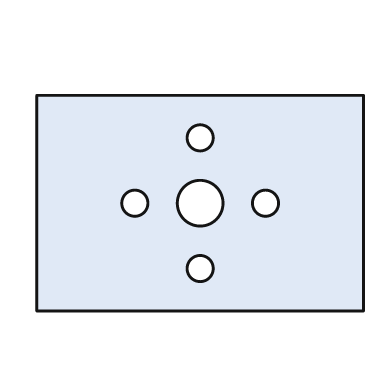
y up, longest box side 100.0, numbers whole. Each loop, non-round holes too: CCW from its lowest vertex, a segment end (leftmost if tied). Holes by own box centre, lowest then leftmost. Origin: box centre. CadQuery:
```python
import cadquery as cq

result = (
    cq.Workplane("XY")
    .moveTo(-50.0, -33.0)
    .lineTo(50.0, -33.0)
    .lineTo(50.0, 33.0)
    .lineTo(-50.0, 33.0)
    .close()
    .moveTo(0.0, -20.0)
    .circle(4.0)
    .moveTo(-20.0, 0.0)
    .circle(4.0)
    .moveTo(0.0, 0.0)
    .circle(7.0)
    .moveTo(20.0, 0.0)
    .circle(4.0)
    .moveTo(0.0, 20.0)
    .circle(4.0)
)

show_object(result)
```